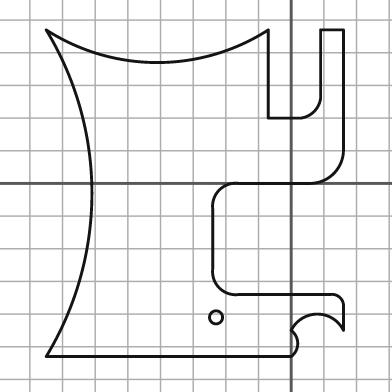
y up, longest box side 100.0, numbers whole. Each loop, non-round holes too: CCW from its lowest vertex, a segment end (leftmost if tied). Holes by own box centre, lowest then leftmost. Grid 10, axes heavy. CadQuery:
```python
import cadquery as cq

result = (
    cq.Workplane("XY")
    .moveTo(-75.0, -53.0)
    .lineTo(0.0, -53.0)
    .threePointArc((2.0, -49.0), (0.0, -45.0))
    .threePointArc((8.0, -40.0), (16.0, -45.0))
    .lineTo(16.0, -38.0)
    .threePointArc((15.0, -35.0), (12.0, -34.0))
    .lineTo(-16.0, -34.0)
    .threePointArc((-22.0, -32.0), (-24.0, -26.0))
    .lineTo(-24.0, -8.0)
    .threePointArc((-22.0, -2.0), (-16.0, 0.0))
    .lineTo(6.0, 0.0)
    .threePointArc((13.0, 3.0), (16.0, 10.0))
    .lineTo(16.0, 47.0)
    .lineTo(9.0, 47.0)
    .lineTo(9.0, 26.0)
    .threePointArc((7.0, 22.0), (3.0, 20.0))
    .lineTo(-7.0, 20.0)
    .lineTo(-7.0, 47.0)
    .threePointArc((-41.0, 37.0), (-75.0, 47.0))
    .threePointArc((-61.0, -3.0), (-75.0, -53.0))
    .close()
    .moveTo(-23.0, -41.0)
    .circle(2.0)
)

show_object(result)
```